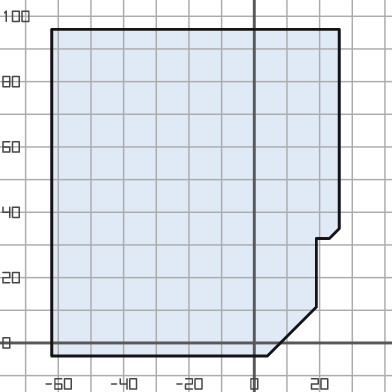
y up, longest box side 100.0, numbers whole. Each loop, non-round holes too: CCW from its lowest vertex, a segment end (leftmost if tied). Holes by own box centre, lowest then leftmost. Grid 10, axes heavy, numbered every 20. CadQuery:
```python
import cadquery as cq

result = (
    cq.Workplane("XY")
    .moveTo(-62.0, -4.0)
    .lineTo(4.0, -4.0)
    .lineTo(19.0, 11.0)
    .lineTo(19.0, 32.0)
    .lineTo(23.0, 32.0)
    .lineTo(26.0, 35.0)
    .lineTo(26.0, 96.0)
    .lineTo(-62.0, 96.0)
    .close()
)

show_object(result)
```